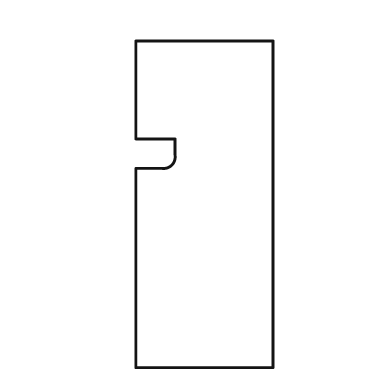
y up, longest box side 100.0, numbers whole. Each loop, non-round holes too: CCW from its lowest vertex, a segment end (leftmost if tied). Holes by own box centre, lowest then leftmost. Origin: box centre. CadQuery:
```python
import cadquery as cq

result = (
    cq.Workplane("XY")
    .moveTo(-21.0, -50.0)
    .lineTo(21.0, -50.0)
    .lineTo(21.0, 50.0)
    .lineTo(-21.0, 50.0)
    .lineTo(-21.0, 20.0)
    .lineTo(-9.0, 20.0)
    .lineTo(-9.0, 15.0)
    .threePointArc((-10.0, 12.0), (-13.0, 11.0))
    .lineTo(-21.0, 11.0)
    .close()
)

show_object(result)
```